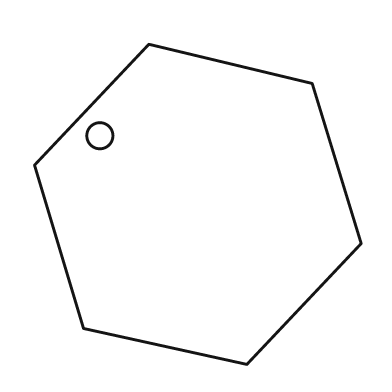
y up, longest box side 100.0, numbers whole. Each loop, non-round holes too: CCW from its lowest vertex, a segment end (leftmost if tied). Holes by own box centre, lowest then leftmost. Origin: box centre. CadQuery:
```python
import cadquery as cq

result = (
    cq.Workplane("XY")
    .moveTo(15.0, -49.0)
    .lineTo(50.0, -12.0)
    .lineTo(35.0, 37.0)
    .lineTo(-15.0, 49.0)
    .lineTo(-50.0, 12.0)
    .lineTo(-35.0, -38.0)
    .close()
    .moveTo(-30.0, 21.0)
    .circle(4.0)
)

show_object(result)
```